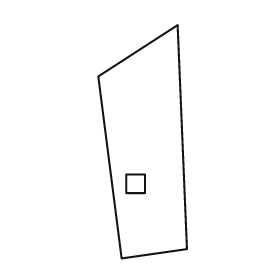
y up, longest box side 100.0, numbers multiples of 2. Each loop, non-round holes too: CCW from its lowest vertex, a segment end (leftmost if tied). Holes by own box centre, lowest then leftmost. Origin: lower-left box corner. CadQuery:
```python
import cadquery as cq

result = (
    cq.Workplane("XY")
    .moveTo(10.0, 0.0)
    .lineTo(38.0, 4.0)
    .lineTo(34.0, 100.0)
    .lineTo(0.0, 78.0)
    .close()
    .moveTo(12.0, 28.0)
    .lineTo(20.0, 28.0)
    .lineTo(20.0, 36.0)
    .lineTo(12.0, 36.0)
    .close()
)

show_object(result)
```